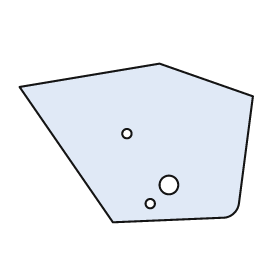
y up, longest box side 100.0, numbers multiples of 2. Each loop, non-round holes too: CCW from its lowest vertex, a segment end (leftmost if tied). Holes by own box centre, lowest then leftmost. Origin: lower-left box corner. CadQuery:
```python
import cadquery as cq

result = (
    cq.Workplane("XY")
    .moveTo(40.0, 0.0)
    .lineTo(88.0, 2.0)
    .threePointArc((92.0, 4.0), (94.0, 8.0))
    .lineTo(100.0, 54.0)
    .lineTo(60.0, 68.0)
    .lineTo(0.0, 58.0)
    .close()
    .moveTo(56.0, 8.0)
    .circle(2.0)
    .moveTo(64.0, 16.0)
    .circle(4.0)
    .moveTo(46.0, 38.0)
    .circle(2.0)
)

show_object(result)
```